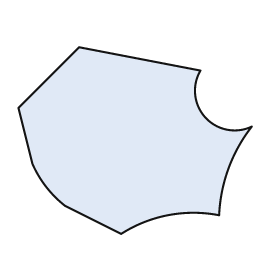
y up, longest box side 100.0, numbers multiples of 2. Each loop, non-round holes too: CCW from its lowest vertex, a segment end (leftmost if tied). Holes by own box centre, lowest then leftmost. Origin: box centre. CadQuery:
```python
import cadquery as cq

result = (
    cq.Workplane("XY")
    .moveTo(-6.0, -40.0)
    .threePointArc((14.0, -32.0), (36.0, -32.0))
    .threePointArc((40.0, -12.0), (50.0, 6.0))
    .threePointArc((30.0, 10.0), (28.0, 30.0))
    .lineTo(-24.0, 40.0)
    .lineTo(-50.0, 14.0)
    .lineTo(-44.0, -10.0)
    .threePointArc((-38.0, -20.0), (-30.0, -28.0))
    .close()
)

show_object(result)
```